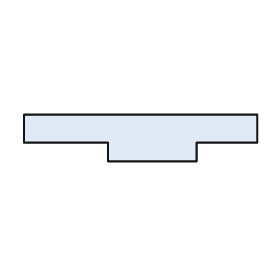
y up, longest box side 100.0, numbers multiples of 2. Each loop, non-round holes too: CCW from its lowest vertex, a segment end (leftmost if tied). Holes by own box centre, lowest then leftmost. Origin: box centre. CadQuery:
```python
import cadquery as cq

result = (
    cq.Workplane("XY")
    .moveTo(-14.0, -10.0)
    .lineTo(24.0, -10.0)
    .lineTo(24.0, -2.0)
    .lineTo(50.0, -2.0)
    .lineTo(50.0, 10.0)
    .lineTo(-50.0, 10.0)
    .lineTo(-50.0, -2.0)
    .lineTo(-14.0, -2.0)
    .close()
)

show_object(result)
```